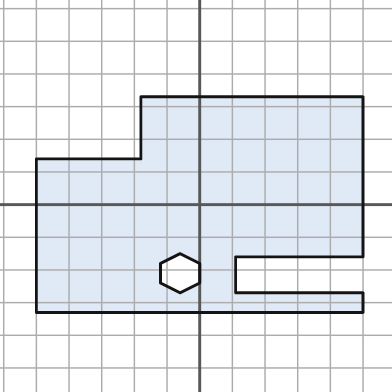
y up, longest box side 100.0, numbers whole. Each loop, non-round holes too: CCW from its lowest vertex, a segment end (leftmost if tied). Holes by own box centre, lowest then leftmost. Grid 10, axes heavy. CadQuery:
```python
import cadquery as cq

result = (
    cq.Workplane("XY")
    .moveTo(-50.0, -33.0)
    .lineTo(50.0, -33.0)
    .lineTo(50.0, -27.0)
    .lineTo(11.0, -27.0)
    .lineTo(11.0, -16.0)
    .lineTo(50.0, -16.0)
    .lineTo(50.0, 33.0)
    .lineTo(-18.0, 33.0)
    .lineTo(-18.0, 14.0)
    .lineTo(-50.0, 14.0)
    .close()
    .moveTo(-6.0, -27.0)
    .lineTo(0.0, -24.0)
    .lineTo(0.0, -18.0)
    .lineTo(-6.0, -15.0)
    .lineTo(-12.0, -18.0)
    .lineTo(-12.0, -24.0)
    .close()
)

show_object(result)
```